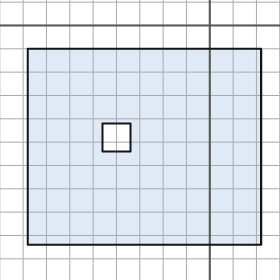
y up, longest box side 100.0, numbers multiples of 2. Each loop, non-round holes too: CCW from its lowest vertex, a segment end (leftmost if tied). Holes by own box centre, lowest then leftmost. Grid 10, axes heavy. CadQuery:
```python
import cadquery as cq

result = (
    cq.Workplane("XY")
    .moveTo(-78.0, -94.0)
    .lineTo(22.0, -94.0)
    .lineTo(22.0, -10.0)
    .lineTo(-78.0, -10.0)
    .close()
    .moveTo(-46.0, -54.0)
    .lineTo(-34.0, -54.0)
    .lineTo(-34.0, -42.0)
    .lineTo(-46.0, -42.0)
    .close()
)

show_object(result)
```